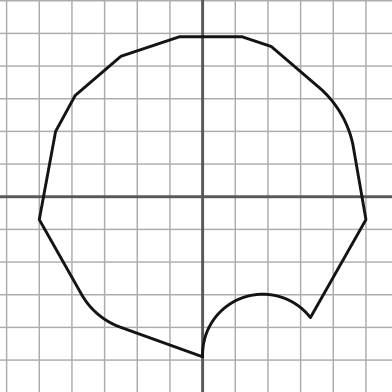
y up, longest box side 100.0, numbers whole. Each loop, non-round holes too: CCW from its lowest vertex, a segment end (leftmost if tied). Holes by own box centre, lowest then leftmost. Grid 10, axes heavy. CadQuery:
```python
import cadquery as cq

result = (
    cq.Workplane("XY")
    .moveTo(0.0, -49.0)
    .threePointArc((12.0, -31.0), (33.0, -37.0))
    .lineTo(50.0, -7.0)
    .lineTo(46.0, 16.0)
    .threePointArc((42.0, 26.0), (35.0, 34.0))
    .lineTo(21.0, 46.0)
    .lineTo(12.0, 49.0)
    .lineTo(-7.0, 49.0)
    .lineTo(-25.0, 43.0)
    .lineTo(-39.0, 31.0)
    .lineTo(-45.0, 20.0)
    .lineTo(-50.0, -7.0)
    .lineTo(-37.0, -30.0)
    .threePointArc((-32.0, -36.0), (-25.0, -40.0))
    .close()
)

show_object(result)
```